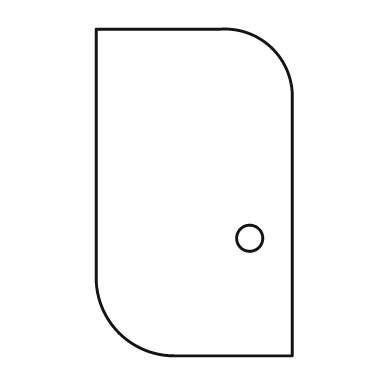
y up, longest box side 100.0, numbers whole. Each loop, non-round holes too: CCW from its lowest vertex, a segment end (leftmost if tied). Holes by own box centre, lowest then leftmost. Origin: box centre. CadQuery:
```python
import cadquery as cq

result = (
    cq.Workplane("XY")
    .moveTo(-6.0, -50.0)
    .lineTo(30.0, -50.0)
    .lineTo(30.0, 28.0)
    .threePointArc((24.0, 44.0), (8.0, 50.0))
    .lineTo(-30.0, 50.0)
    .lineTo(-30.0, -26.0)
    .threePointArc((-23.0, -43.0), (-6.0, -50.0))
    .close()
    .moveTo(17.0, -14.0)
    .circle(4.0)
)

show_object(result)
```